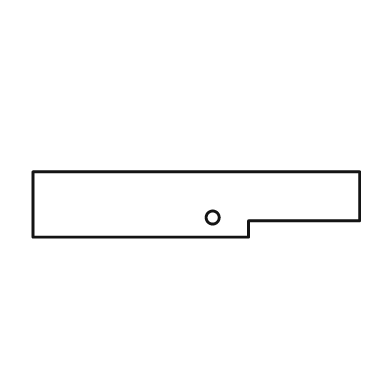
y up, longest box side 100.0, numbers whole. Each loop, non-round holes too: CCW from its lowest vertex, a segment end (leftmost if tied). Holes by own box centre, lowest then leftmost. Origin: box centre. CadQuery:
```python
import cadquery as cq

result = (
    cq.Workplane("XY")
    .moveTo(-50.0, -10.0)
    .lineTo(16.0, -10.0)
    .lineTo(16.0, -5.0)
    .lineTo(50.0, -5.0)
    .lineTo(50.0, 10.0)
    .lineTo(-50.0, 10.0)
    .close()
    .moveTo(5.0, -4.0)
    .circle(2.0)
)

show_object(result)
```